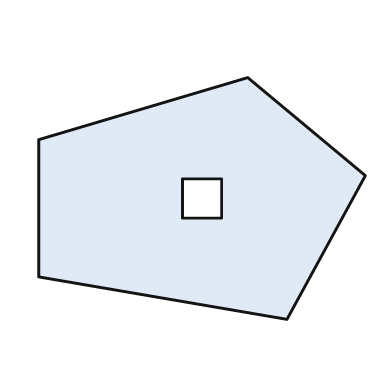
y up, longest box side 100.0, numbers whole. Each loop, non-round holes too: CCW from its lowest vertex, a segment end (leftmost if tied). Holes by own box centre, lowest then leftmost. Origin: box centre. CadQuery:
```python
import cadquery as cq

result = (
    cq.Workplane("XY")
    .moveTo(26.0, -37.0)
    .lineTo(50.0, 7.0)
    .lineTo(14.0, 37.0)
    .lineTo(-50.0, 18.0)
    .lineTo(-50.0, -24.0)
    .close()
    .moveTo(-6.0, -6.0)
    .lineTo(6.0, -6.0)
    .lineTo(6.0, 6.0)
    .lineTo(-6.0, 6.0)
    .close()
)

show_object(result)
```